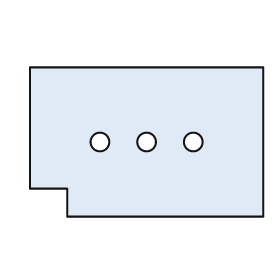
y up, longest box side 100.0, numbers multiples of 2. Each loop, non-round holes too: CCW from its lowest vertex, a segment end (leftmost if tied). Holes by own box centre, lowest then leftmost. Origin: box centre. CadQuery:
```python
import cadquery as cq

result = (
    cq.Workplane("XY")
    .moveTo(-34.0, -32.0)
    .lineTo(50.0, -32.0)
    .lineTo(50.0, 32.0)
    .lineTo(-50.0, 32.0)
    .lineTo(-50.0, -20.0)
    .lineTo(-34.0, -20.0)
    .close()
    .moveTo(-20.0, 0.0)
    .circle(4.0)
    .moveTo(0.0, 0.0)
    .circle(4.0)
    .moveTo(20.0, 0.0)
    .circle(4.0)
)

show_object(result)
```